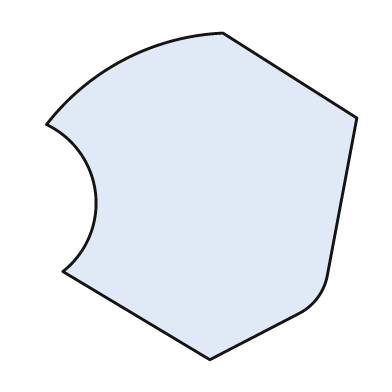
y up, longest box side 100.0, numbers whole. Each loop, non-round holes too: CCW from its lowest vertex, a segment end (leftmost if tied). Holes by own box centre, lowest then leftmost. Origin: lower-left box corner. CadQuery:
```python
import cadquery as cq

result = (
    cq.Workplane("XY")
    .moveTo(50.0, 0.0)
    .lineTo(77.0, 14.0)
    .threePointArc((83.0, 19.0), (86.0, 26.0))
    .lineTo(95.0, 74.0)
    .lineTo(54.0, 100.0)
    .threePointArc((24.0, 92.0), (0.0, 72.0))
    .threePointArc((15.0, 51.0), (5.0, 27.0))
    .close()
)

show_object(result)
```